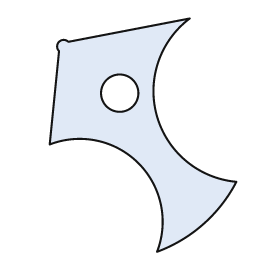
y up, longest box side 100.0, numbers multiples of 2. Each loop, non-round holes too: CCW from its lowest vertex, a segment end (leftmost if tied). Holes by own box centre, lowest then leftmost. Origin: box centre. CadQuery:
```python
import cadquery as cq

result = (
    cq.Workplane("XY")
    .moveTo(6.0, -50.0)
    .threePointArc((26.0, -38.0), (40.0, -20.0))
    .threePointArc((6.0, 8.0), (20.0, 50.0))
    .lineTo(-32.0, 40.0)
    .threePointArc((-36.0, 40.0), (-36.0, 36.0))
    .lineTo(-40.0, -4.0)
    .threePointArc((-2.0, -12.0), (6.0, -50.0))
    .close()
    .moveTo(-10.0, 18.0)
    .circle(8.0)
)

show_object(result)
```